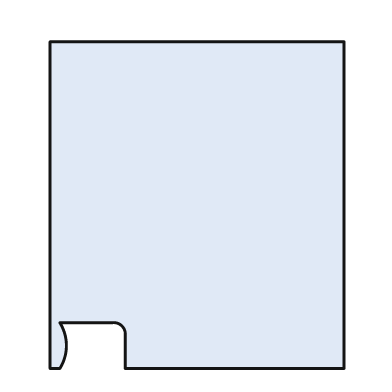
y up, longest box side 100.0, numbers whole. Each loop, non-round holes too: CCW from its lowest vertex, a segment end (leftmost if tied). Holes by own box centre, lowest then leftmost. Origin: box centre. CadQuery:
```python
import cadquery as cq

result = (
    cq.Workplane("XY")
    .moveTo(-45.0, -50.0)
    .lineTo(-42.0, -50.0)
    .threePointArc((-40.0, -43.0), (-42.0, -36.0))
    .lineTo(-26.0, -36.0)
    .threePointArc((-23.0, -37.0), (-22.0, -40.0))
    .lineTo(-22.0, -50.0)
    .lineTo(45.0, -50.0)
    .lineTo(45.0, 50.0)
    .lineTo(-45.0, 50.0)
    .close()
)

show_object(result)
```